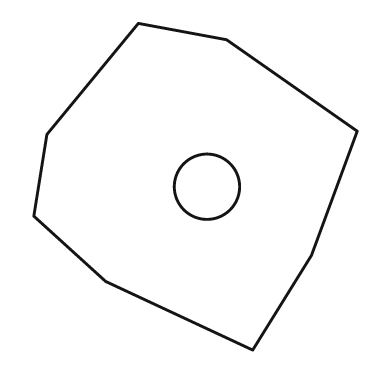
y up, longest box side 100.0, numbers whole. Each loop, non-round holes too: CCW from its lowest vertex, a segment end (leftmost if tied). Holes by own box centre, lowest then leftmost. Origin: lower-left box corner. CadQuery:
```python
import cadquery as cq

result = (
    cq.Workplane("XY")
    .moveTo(67.0, 0.0)
    .lineTo(85.0, 29.0)
    .lineTo(99.0, 67.0)
    .lineTo(59.0, 95.0)
    .lineTo(32.0, 100.0)
    .lineTo(4.0, 66.0)
    .lineTo(0.0, 41.0)
    .lineTo(22.0, 21.0)
    .close()
    .moveTo(53.0, 50.0)
    .circle(10.0)
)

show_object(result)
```